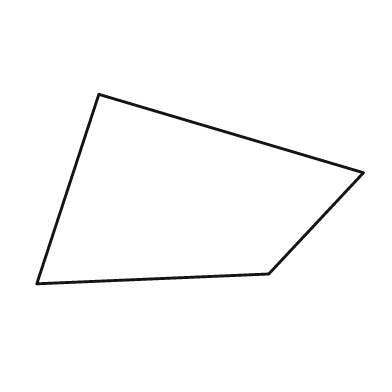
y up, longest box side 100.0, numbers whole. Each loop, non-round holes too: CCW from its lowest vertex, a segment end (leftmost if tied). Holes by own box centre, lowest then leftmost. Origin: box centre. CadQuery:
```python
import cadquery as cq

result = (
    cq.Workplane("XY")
    .moveTo(-50.0, -29.0)
    .lineTo(21.0, -26.0)
    .lineTo(50.0, 5.0)
    .lineTo(-31.0, 29.0)
    .close()
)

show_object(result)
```